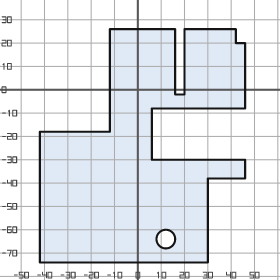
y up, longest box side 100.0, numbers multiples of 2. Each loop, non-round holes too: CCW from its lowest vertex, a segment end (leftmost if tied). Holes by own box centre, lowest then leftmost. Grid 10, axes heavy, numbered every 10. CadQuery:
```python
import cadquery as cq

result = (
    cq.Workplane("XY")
    .moveTo(-42.0, -74.0)
    .lineTo(30.0, -74.0)
    .lineTo(30.0, -38.0)
    .lineTo(46.0, -38.0)
    .lineTo(46.0, -30.0)
    .lineTo(6.0, -30.0)
    .lineTo(6.0, -8.0)
    .lineTo(46.0, -8.0)
    .lineTo(46.0, 20.0)
    .lineTo(42.0, 20.0)
    .lineTo(42.0, 26.0)
    .lineTo(20.0, 26.0)
    .lineTo(20.0, -2.0)
    .lineTo(16.0, -2.0)
    .lineTo(16.0, 26.0)
    .lineTo(-12.0, 26.0)
    .lineTo(-12.0, -18.0)
    .lineTo(-42.0, -18.0)
    .close()
    .moveTo(12.0, -64.0)
    .circle(4.0)
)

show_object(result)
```